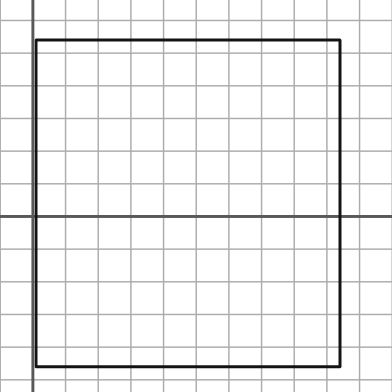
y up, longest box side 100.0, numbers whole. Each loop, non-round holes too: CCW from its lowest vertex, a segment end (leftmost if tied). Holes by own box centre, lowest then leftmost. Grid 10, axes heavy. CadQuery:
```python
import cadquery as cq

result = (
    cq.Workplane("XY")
    .moveTo(1.0, -46.0)
    .lineTo(94.0, -46.0)
    .lineTo(94.0, 54.0)
    .lineTo(1.0, 54.0)
    .close()
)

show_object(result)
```